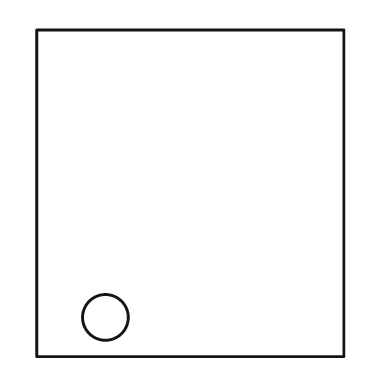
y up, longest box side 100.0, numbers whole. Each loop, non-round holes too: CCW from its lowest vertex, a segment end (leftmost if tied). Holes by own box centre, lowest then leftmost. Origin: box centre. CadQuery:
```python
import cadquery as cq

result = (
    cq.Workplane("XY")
    .moveTo(-47.0, -50.0)
    .lineTo(47.0, -50.0)
    .lineTo(47.0, 50.0)
    .lineTo(-47.0, 50.0)
    .close()
    .moveTo(-26.0, -38.0)
    .circle(7.0)
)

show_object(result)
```